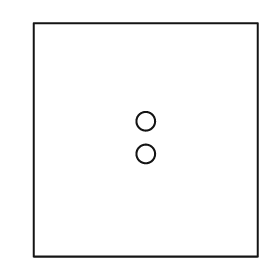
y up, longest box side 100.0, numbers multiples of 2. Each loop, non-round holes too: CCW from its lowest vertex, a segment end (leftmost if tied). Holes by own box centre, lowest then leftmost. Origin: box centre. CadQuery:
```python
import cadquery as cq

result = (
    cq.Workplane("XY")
    .moveTo(-48.0, -50.0)
    .lineTo(48.0, -50.0)
    .lineTo(48.0, 50.0)
    .lineTo(-48.0, 50.0)
    .close()
    .moveTo(0.0, -6.0)
    .circle(4.0)
    .moveTo(0.0, 8.0)
    .circle(4.0)
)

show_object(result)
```